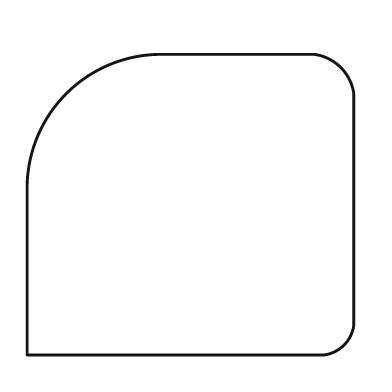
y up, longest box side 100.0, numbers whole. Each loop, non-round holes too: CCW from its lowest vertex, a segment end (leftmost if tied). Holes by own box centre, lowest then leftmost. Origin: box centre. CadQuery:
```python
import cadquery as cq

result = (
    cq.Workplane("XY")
    .moveTo(-50.0, -46.0)
    .lineTo(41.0, -46.0)
    .threePointArc((47.0, -43.0), (50.0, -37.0))
    .lineTo(50.0, 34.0)
    .threePointArc((46.0, 42.0), (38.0, 46.0))
    .lineTo(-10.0, 46.0)
    .threePointArc((-38.0, 34.0), (-50.0, 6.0))
    .close()
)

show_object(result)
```